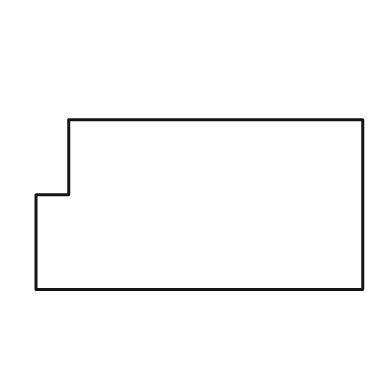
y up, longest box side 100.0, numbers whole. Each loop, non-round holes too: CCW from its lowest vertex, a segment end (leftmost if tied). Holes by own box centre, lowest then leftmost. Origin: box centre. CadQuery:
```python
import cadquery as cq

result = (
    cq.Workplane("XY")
    .moveTo(-50.0, -26.0)
    .lineTo(50.0, -26.0)
    .lineTo(50.0, 26.0)
    .lineTo(-40.0, 26.0)
    .lineTo(-40.0, 3.0)
    .lineTo(-50.0, 3.0)
    .close()
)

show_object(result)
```